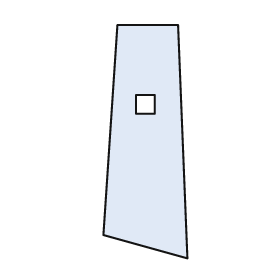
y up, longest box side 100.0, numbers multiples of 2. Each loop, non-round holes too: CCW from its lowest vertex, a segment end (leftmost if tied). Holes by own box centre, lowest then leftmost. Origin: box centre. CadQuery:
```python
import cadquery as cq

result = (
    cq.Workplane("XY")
    .moveTo(18.0, -50.0)
    .lineTo(14.0, 50.0)
    .lineTo(-12.0, 50.0)
    .lineTo(-18.0, -40.0)
    .close()
    .moveTo(-4.0, 12.0)
    .lineTo(4.0, 12.0)
    .lineTo(4.0, 20.0)
    .lineTo(-4.0, 20.0)
    .close()
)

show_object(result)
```